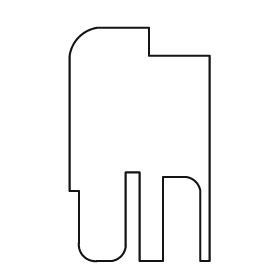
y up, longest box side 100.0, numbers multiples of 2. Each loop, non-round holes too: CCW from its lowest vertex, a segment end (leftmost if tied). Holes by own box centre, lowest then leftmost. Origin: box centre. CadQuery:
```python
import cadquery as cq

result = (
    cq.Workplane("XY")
    .moveTo(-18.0, -50.0)
    .lineTo(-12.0, -50.0)
    .threePointArc((-8.0, -48.0), (-6.0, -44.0))
    .lineTo(-6.0, -12.0)
    .lineTo(0.0, -12.0)
    .lineTo(0.0, -50.0)
    .lineTo(10.0, -50.0)
    .lineTo(10.0, -14.0)
    .lineTo(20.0, -14.0)
    .threePointArc((24.0, -16.0), (26.0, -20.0))
    .lineTo(26.0, -50.0)
    .lineTo(30.0, -50.0)
    .lineTo(30.0, 38.0)
    .lineTo(4.0, 38.0)
    .lineTo(4.0, 50.0)
    .lineTo(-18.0, 50.0)
    .threePointArc((-26.0, 46.0), (-30.0, 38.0))
    .lineTo(-30.0, -20.0)
    .lineTo(-26.0, -20.0)
    .lineTo(-26.0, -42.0)
    .threePointArc((-24.0, -48.0), (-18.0, -50.0))
    .close()
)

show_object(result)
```